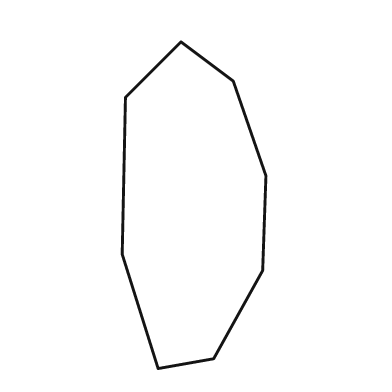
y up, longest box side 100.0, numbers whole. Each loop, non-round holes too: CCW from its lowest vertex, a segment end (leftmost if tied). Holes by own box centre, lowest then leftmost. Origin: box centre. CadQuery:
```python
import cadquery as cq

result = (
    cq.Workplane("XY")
    .moveTo(-11.0, -50.0)
    .lineTo(6.0, -47.0)
    .lineTo(21.0, -20.0)
    .lineTo(22.0, 9.0)
    .lineTo(12.0, 38.0)
    .lineTo(-4.0, 50.0)
    .lineTo(-21.0, 33.0)
    .lineTo(-22.0, -15.0)
    .close()
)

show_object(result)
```